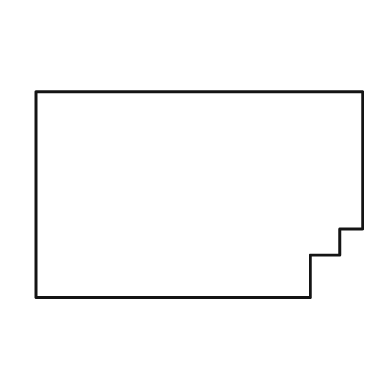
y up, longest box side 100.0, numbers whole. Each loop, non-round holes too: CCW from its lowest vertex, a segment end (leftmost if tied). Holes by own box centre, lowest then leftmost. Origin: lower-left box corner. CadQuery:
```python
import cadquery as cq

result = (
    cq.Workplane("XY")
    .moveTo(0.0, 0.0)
    .lineTo(84.0, 0.0)
    .lineTo(84.0, 13.0)
    .lineTo(93.0, 13.0)
    .lineTo(93.0, 21.0)
    .lineTo(100.0, 21.0)
    .lineTo(100.0, 63.0)
    .lineTo(0.0, 63.0)
    .close()
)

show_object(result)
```